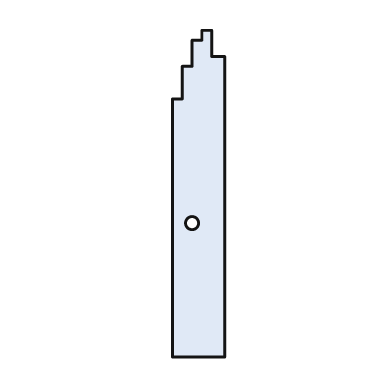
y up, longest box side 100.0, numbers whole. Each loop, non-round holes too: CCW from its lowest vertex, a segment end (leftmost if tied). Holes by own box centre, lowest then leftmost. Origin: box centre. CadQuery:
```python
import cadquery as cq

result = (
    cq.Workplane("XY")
    .moveTo(-8.0, -50.0)
    .lineTo(8.0, -50.0)
    .lineTo(8.0, 42.0)
    .lineTo(4.0, 42.0)
    .lineTo(4.0, 50.0)
    .lineTo(1.0, 50.0)
    .lineTo(1.0, 47.0)
    .lineTo(-2.0, 47.0)
    .lineTo(-2.0, 39.0)
    .lineTo(-5.0, 39.0)
    .lineTo(-5.0, 29.0)
    .lineTo(-8.0, 29.0)
    .close()
    .moveTo(-2.0, -9.0)
    .circle(2.0)
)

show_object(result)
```